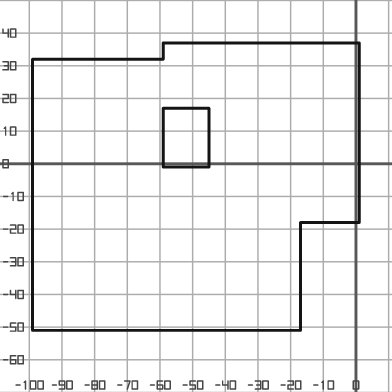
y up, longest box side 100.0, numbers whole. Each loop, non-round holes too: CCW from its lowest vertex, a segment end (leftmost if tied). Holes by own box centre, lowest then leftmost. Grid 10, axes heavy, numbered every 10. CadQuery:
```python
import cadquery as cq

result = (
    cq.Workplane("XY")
    .moveTo(-99.0, -51.0)
    .lineTo(-17.0, -51.0)
    .lineTo(-17.0, -18.0)
    .lineTo(1.0, -18.0)
    .lineTo(1.0, 37.0)
    .lineTo(-59.0, 37.0)
    .lineTo(-59.0, 32.0)
    .lineTo(-99.0, 32.0)
    .close()
    .moveTo(-59.0, -1.0)
    .lineTo(-45.0, -1.0)
    .lineTo(-45.0, 17.0)
    .lineTo(-59.0, 17.0)
    .close()
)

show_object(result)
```